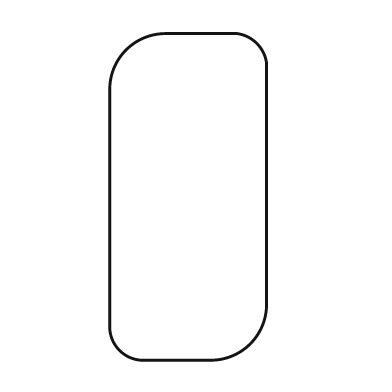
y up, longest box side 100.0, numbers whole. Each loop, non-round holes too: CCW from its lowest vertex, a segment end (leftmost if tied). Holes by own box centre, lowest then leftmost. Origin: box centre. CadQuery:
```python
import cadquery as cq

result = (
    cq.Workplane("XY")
    .moveTo(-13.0, -50.0)
    .lineTo(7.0, -50.0)
    .threePointArc((19.0, -45.0), (24.0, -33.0))
    .lineTo(24.0, 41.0)
    .threePointArc((21.0, 47.0), (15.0, 50.0))
    .lineTo(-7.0, 50.0)
    .threePointArc((-19.0, 45.0), (-24.0, 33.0))
    .lineTo(-24.0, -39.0)
    .threePointArc((-21.0, -47.0), (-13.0, -50.0))
    .close()
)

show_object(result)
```